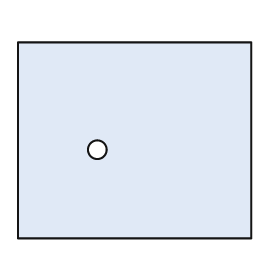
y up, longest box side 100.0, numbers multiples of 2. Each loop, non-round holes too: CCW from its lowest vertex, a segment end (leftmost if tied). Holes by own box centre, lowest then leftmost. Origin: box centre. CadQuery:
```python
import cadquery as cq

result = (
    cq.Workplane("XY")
    .moveTo(-50.0, -42.0)
    .lineTo(50.0, -42.0)
    .lineTo(50.0, 42.0)
    .lineTo(-50.0, 42.0)
    .close()
    .moveTo(-16.0, -4.0)
    .circle(4.0)
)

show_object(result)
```